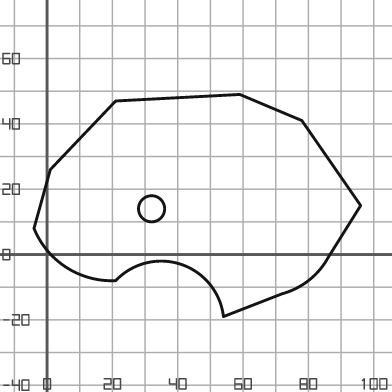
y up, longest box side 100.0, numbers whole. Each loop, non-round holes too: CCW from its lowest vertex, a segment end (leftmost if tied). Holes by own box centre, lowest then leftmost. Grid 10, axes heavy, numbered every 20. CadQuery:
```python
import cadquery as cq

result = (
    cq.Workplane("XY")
    .moveTo(54.0, -19.0)
    .lineTo(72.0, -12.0)
    .threePointArc((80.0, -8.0), (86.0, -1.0))
    .lineTo(96.0, 15.0)
    .lineTo(78.0, 41.0)
    .lineTo(59.0, 49.0)
    .lineTo(21.0, 47.0)
    .lineTo(1.0, 26.0)
    .lineTo(-4.0, 8.0)
    .threePointArc((6.0, -4.0), (21.0, -8.0))
    .threePointArc((41.0, -3.0), (54.0, -19.0))
    .close()
    .moveTo(32.0, 14.0)
    .circle(4.0)
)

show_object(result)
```